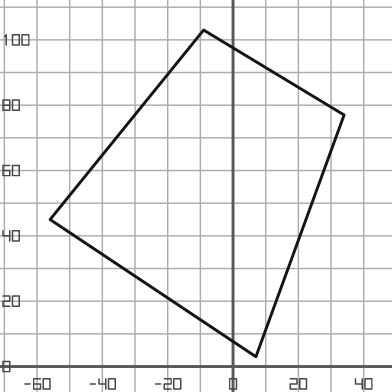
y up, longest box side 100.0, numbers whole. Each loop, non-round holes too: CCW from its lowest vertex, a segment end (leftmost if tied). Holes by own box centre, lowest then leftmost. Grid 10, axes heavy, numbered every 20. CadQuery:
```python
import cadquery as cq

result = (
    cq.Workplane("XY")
    .moveTo(7.0, 3.0)
    .lineTo(34.0, 77.0)
    .lineTo(-9.0, 103.0)
    .lineTo(-56.0, 45.0)
    .close()
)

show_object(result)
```